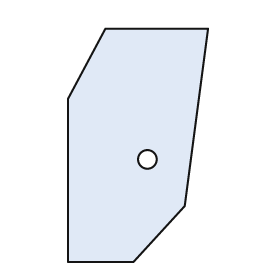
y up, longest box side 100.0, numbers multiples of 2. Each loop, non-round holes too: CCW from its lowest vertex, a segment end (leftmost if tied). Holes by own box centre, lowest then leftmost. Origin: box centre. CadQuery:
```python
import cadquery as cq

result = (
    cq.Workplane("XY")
    .moveTo(-30.0, -50.0)
    .lineTo(-2.0, -50.0)
    .lineTo(20.0, -26.0)
    .lineTo(30.0, 50.0)
    .lineTo(-14.0, 50.0)
    .lineTo(-30.0, 20.0)
    .close()
    .moveTo(4.0, -6.0)
    .circle(4.0)
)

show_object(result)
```